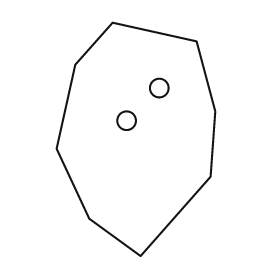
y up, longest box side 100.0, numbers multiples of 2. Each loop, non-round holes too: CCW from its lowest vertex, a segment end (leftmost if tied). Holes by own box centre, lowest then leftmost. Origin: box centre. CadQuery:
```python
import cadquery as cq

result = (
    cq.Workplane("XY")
    .moveTo(2.0, -50.0)
    .lineTo(32.0, -16.0)
    .lineTo(34.0, 12.0)
    .lineTo(26.0, 42.0)
    .lineTo(-10.0, 50.0)
    .lineTo(-26.0, 32.0)
    .lineTo(-34.0, -4.0)
    .lineTo(-20.0, -34.0)
    .close()
    .moveTo(-4.0, 8.0)
    .circle(4.0)
    .moveTo(10.0, 22.0)
    .circle(4.0)
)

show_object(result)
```